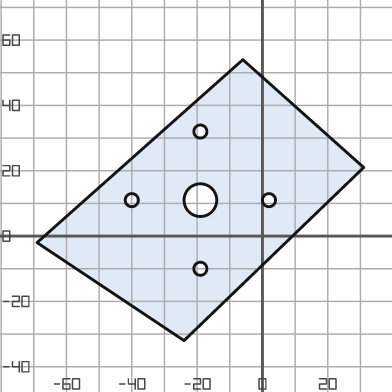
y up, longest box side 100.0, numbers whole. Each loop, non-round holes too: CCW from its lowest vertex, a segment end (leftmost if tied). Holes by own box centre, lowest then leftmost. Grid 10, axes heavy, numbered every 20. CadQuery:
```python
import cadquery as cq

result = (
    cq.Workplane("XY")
    .moveTo(-24.0, -32.0)
    .lineTo(31.0, 21.0)
    .lineTo(-6.0, 54.0)
    .lineTo(-69.0, -2.0)
    .close()
    .moveTo(-19.0, -10.0)
    .circle(2.0)
    .moveTo(-40.0, 11.0)
    .circle(2.0)
    .moveTo(-19.0, 11.0)
    .circle(5.0)
    .moveTo(2.0, 11.0)
    .circle(2.0)
    .moveTo(-19.0, 32.0)
    .circle(2.0)
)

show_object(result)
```